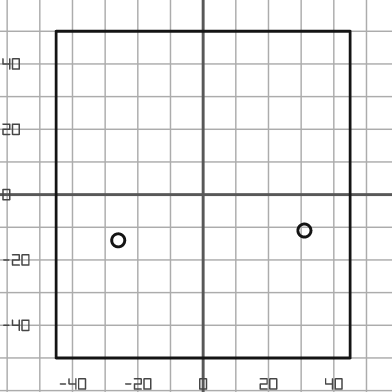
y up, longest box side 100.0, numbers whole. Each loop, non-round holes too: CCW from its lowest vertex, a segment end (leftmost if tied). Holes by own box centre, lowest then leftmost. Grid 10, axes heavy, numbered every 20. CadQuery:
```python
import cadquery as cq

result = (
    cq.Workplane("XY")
    .moveTo(-45.0, -50.0)
    .lineTo(45.0, -50.0)
    .lineTo(45.0, 50.0)
    .lineTo(-45.0, 50.0)
    .close()
    .moveTo(-26.0, -14.0)
    .circle(2.0)
    .moveTo(31.0, -11.0)
    .circle(2.0)
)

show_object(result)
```